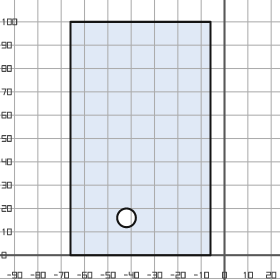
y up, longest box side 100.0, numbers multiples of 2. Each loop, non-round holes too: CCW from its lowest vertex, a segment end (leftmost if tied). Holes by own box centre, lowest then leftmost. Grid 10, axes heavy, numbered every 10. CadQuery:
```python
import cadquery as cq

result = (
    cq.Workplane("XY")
    .moveTo(-66.0, 0.0)
    .lineTo(-6.0, 0.0)
    .lineTo(-6.0, 100.0)
    .lineTo(-66.0, 100.0)
    .close()
    .moveTo(-42.0, 16.0)
    .circle(4.0)
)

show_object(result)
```